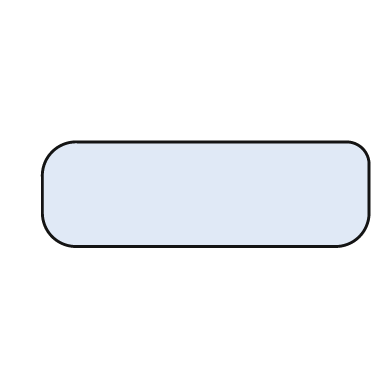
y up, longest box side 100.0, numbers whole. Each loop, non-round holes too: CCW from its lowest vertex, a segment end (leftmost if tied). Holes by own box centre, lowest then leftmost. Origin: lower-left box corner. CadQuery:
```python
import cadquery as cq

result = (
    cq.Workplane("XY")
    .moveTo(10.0, 0.0)
    .lineTo(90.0, 0.0)
    .threePointArc((97.0, 3.0), (100.0, 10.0))
    .lineTo(100.0, 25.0)
    .threePointArc((98.0, 30.0), (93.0, 32.0))
    .lineTo(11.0, 32.0)
    .threePointArc((3.0, 29.0), (0.0, 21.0))
    .lineTo(0.0, 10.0)
    .threePointArc((3.0, 3.0), (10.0, 0.0))
    .close()
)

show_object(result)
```